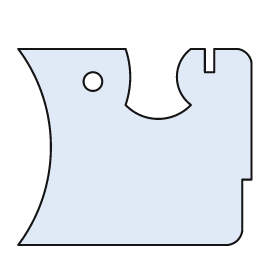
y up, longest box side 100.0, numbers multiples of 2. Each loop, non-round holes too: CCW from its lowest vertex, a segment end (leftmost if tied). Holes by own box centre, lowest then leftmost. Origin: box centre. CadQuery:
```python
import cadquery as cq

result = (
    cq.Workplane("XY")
    .moveTo(-50.0, -42.0)
    .lineTo(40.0, -42.0)
    .threePointArc((44.0, -40.0), (46.0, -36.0))
    .lineTo(46.0, -14.0)
    .lineTo(50.0, -14.0)
    .lineTo(50.0, 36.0)
    .threePointArc((48.0, 40.0), (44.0, 42.0))
    .lineTo(34.0, 42.0)
    .lineTo(34.0, 32.0)
    .lineTo(30.0, 32.0)
    .lineTo(30.0, 42.0)
    .lineTo(24.0, 42.0)
    .threePointArc((18.0, 30.0), (24.0, 18.0))
    .threePointArc((10.0, 12.0), (-4.0, 18.0))
    .threePointArc((-2.0, 30.0), (-4.0, 42.0))
    .lineTo(-50.0, 42.0)
    .threePointArc((-36.0, 0.0), (-50.0, -42.0))
    .close()
    .moveTo(-18.0, 28.0)
    .circle(4.0)
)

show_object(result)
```